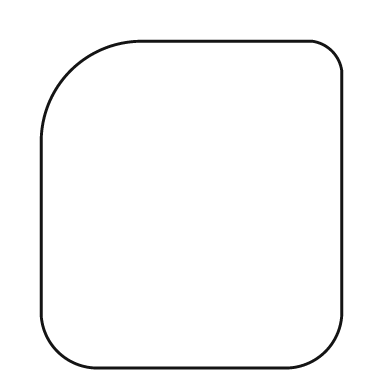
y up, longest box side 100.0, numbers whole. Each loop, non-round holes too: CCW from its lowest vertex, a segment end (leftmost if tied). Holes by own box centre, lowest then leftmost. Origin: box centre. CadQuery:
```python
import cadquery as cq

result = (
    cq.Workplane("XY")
    .moveTo(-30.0, -50.0)
    .lineTo(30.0, -50.0)
    .threePointArc((41.0, -45.0), (46.0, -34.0))
    .lineTo(46.0, 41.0)
    .threePointArc((43.0, 47.0), (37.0, 50.0))
    .lineTo(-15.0, 50.0)
    .threePointArc((-37.0, 41.0), (-46.0, 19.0))
    .lineTo(-46.0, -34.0)
    .threePointArc((-41.0, -45.0), (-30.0, -50.0))
    .close()
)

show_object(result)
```